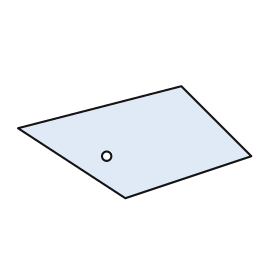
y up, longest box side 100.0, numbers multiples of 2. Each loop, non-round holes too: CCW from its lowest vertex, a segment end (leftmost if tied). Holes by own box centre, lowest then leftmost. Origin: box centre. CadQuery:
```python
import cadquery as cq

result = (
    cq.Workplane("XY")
    .moveTo(-4.0, -24.0)
    .lineTo(50.0, -6.0)
    .lineTo(20.0, 24.0)
    .lineTo(-50.0, 6.0)
    .close()
    .moveTo(-12.0, -6.0)
    .circle(2.0)
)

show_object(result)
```